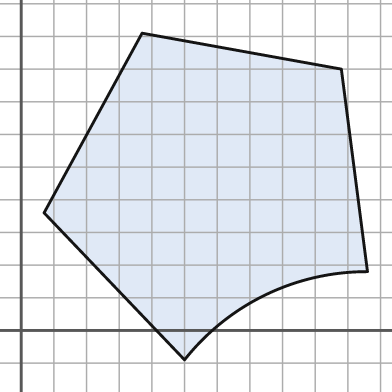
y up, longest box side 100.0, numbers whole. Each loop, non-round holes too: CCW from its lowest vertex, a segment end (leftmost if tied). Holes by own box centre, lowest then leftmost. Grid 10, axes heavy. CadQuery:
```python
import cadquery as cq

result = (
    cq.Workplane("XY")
    .moveTo(50.0, -9.0)
    .threePointArc((75.0, 11.0), (106.0, 18.0))
    .lineTo(98.0, 80.0)
    .lineTo(37.0, 91.0)
    .lineTo(7.0, 36.0)
    .close()
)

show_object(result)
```